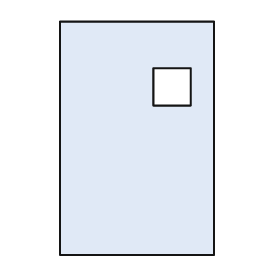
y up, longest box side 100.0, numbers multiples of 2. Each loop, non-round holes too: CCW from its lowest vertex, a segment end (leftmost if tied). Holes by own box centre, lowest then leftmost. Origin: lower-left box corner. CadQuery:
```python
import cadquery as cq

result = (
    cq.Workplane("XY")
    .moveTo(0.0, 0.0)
    .lineTo(66.0, 0.0)
    .lineTo(66.0, 100.0)
    .lineTo(0.0, 100.0)
    .close()
    .moveTo(40.0, 64.0)
    .lineTo(56.0, 64.0)
    .lineTo(56.0, 80.0)
    .lineTo(40.0, 80.0)
    .close()
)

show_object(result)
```